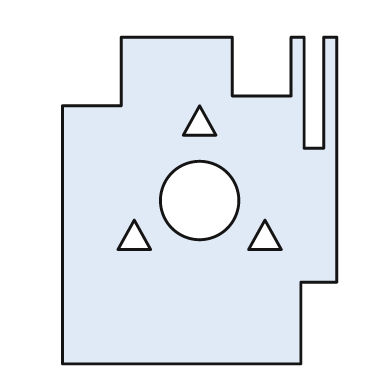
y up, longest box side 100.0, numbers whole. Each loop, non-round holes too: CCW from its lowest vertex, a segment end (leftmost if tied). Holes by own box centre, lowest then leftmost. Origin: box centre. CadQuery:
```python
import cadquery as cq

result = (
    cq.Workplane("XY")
    .moveTo(-42.0, -50.0)
    .lineTo(31.0, -50.0)
    .lineTo(31.0, -25.0)
    .lineTo(42.0, -25.0)
    .lineTo(42.0, 50.0)
    .lineTo(38.0, 50.0)
    .lineTo(38.0, 16.0)
    .lineTo(32.0, 16.0)
    .lineTo(32.0, 50.0)
    .lineTo(28.0, 50.0)
    .lineTo(28.0, 32.0)
    .lineTo(10.0, 32.0)
    .lineTo(10.0, 50.0)
    .lineTo(-24.0, 50.0)
    .lineTo(-24.0, 29.0)
    .lineTo(-42.0, 29.0)
    .close()
    .moveTo(-25.0, -15.0)
    .lineTo(-15.0, -15.0)
    .lineTo(-20.0, -6.0)
    .close()
    .moveTo(15.0, -15.0)
    .lineTo(25.0, -15.0)
    .lineTo(20.0, -6.0)
    .close()
    .moveTo(0.0, 0.0)
    .circle(12.0)
    .moveTo(-5.0, 20.0)
    .lineTo(5.0, 20.0)
    .lineTo(0.0, 29.0)
    .close()
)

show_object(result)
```